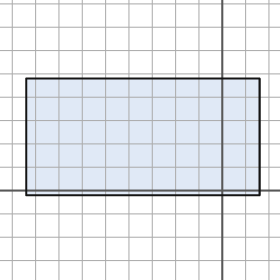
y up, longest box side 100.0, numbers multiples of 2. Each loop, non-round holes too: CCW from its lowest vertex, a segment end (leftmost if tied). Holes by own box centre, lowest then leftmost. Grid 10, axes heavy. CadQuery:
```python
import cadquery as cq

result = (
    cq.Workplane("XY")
    .moveTo(-84.0, -2.0)
    .lineTo(16.0, -2.0)
    .lineTo(16.0, 48.0)
    .lineTo(-84.0, 48.0)
    .close()
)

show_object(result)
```